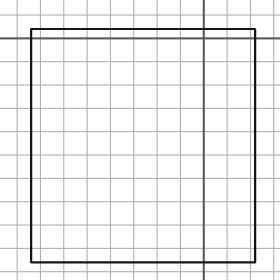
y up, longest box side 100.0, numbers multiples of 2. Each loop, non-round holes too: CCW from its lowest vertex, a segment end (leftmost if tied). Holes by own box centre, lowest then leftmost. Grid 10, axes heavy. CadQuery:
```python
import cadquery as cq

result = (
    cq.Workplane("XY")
    .moveTo(-74.0, -96.0)
    .lineTo(22.0, -96.0)
    .lineTo(22.0, 4.0)
    .lineTo(-74.0, 4.0)
    .close()
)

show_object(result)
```